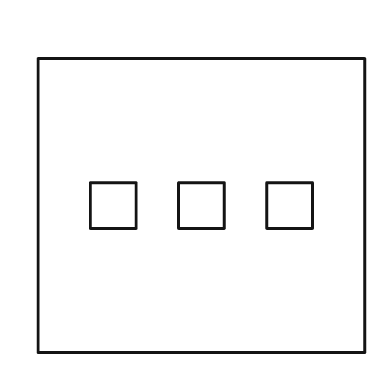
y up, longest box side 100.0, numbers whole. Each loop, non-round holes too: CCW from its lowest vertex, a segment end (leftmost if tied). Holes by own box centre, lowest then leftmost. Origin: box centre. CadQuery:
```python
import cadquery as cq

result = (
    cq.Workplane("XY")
    .moveTo(-50.0, -45.0)
    .lineTo(50.0, -45.0)
    .lineTo(50.0, 45.0)
    .lineTo(-50.0, 45.0)
    .close()
    .moveTo(-34.0, -7.0)
    .lineTo(-20.0, -7.0)
    .lineTo(-20.0, 7.0)
    .lineTo(-34.0, 7.0)
    .close()
    .moveTo(-7.0, -7.0)
    .lineTo(7.0, -7.0)
    .lineTo(7.0, 7.0)
    .lineTo(-7.0, 7.0)
    .close()
    .moveTo(20.0, -7.0)
    .lineTo(34.0, -7.0)
    .lineTo(34.0, 7.0)
    .lineTo(20.0, 7.0)
    .close()
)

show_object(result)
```